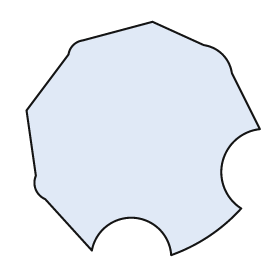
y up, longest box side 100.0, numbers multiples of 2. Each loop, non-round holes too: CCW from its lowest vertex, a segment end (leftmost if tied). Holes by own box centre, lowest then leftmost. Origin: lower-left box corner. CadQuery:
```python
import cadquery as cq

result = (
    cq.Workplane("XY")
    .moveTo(62.0, 0.0)
    .threePointArc((78.0, 8.0), (92.0, 20.0))
    .threePointArc((84.0, 40.0), (100.0, 54.0))
    .lineTo(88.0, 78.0)
    .threePointArc((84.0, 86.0), (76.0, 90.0))
    .lineTo(54.0, 100.0)
    .lineTo(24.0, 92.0)
    .threePointArc((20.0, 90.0), (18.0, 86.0))
    .lineTo(0.0, 62.0)
    .lineTo(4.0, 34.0)
    .threePointArc((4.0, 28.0), (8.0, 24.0))
    .lineTo(28.0, 2.0)
    .threePointArc((46.0, 16.0), (62.0, 0.0))
    .close()
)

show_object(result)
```